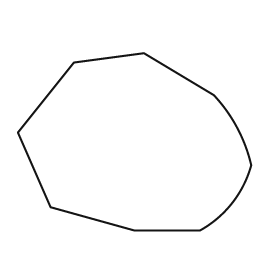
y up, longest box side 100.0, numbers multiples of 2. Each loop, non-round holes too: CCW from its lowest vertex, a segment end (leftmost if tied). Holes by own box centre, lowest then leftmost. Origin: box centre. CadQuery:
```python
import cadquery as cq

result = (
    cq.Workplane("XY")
    .moveTo(0.0, -38.0)
    .lineTo(28.0, -38.0)
    .threePointArc((42.0, -26.0), (50.0, -10.0))
    .threePointArc((44.0, 6.0), (34.0, 20.0))
    .lineTo(4.0, 38.0)
    .lineTo(-26.0, 34.0)
    .lineTo(-50.0, 4.0)
    .lineTo(-36.0, -28.0)
    .close()
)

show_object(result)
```